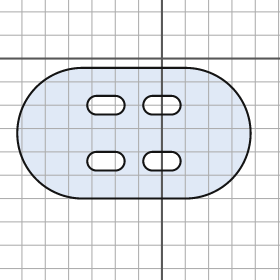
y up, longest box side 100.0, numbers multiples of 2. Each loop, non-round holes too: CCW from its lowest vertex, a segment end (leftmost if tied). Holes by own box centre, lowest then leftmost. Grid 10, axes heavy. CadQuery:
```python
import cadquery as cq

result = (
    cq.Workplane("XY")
    .moveTo(-34.0, -60.0)
    .lineTo(10.0, -60.0)
    .threePointArc((38.0, -32.0), (10.0, -4.0))
    .lineTo(-34.0, -4.0)
    .threePointArc((-62.0, -32.0), (-34.0, -60.0))
    .close()
    .moveTo(-28.0, -48.0)
    .lineTo(-20.0, -48.0)
    .threePointArc((-16.0, -44.0), (-20.0, -40.0))
    .lineTo(-28.0, -40.0)
    .threePointArc((-32.0, -44.0), (-28.0, -48.0))
    .close()
    .moveTo(-4.0, -48.0)
    .lineTo(4.0, -48.0)
    .threePointArc((8.0, -44.0), (4.0, -40.0))
    .lineTo(-4.0, -40.0)
    .threePointArc((-8.0, -44.0), (-4.0, -48.0))
    .close()
    .moveTo(-28.0, -24.0)
    .lineTo(-20.0, -24.0)
    .threePointArc((-16.0, -20.0), (-20.0, -16.0))
    .lineTo(-28.0, -16.0)
    .threePointArc((-32.0, -20.0), (-28.0, -24.0))
    .close()
    .moveTo(-4.0, -24.0)
    .lineTo(4.0, -24.0)
    .threePointArc((8.0, -20.0), (4.0, -16.0))
    .lineTo(-4.0, -16.0)
    .threePointArc((-8.0, -20.0), (-4.0, -24.0))
    .close()
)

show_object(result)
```